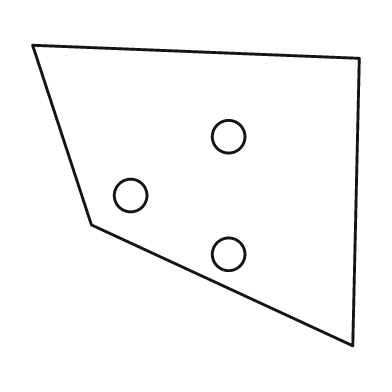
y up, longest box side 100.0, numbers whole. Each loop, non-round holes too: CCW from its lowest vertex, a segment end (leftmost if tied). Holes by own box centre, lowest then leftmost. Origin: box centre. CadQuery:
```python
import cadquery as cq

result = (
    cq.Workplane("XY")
    .moveTo(48.0, -46.0)
    .lineTo(50.0, 42.0)
    .lineTo(-50.0, 46.0)
    .lineTo(-32.0, -9.0)
    .close()
    .moveTo(10.0, -18.0)
    .circle(5.0)
    .moveTo(-20.0, 0.0)
    .circle(5.0)
    .moveTo(10.0, 18.0)
    .circle(5.0)
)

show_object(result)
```